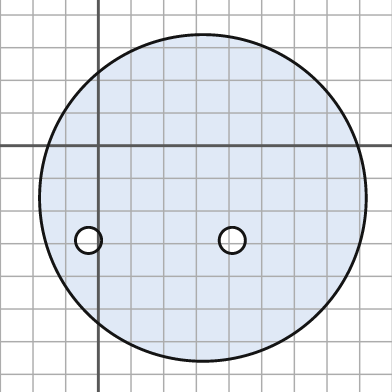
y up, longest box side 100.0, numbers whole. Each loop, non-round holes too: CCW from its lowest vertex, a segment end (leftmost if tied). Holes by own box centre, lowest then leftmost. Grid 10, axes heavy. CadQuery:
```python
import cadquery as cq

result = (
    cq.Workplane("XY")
    .moveTo(32.0, -16.0)
    .circle(50.0)
    .moveTo(-3.0, -29.0)
    .circle(4.0)
    .moveTo(41.0, -29.0)
    .circle(4.0)
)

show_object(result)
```